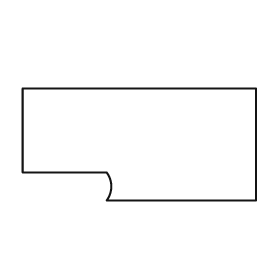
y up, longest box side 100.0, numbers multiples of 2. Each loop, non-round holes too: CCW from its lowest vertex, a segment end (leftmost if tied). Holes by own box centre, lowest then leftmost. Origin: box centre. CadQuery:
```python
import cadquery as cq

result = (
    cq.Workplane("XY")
    .moveTo(-14.0, -24.0)
    .lineTo(50.0, -24.0)
    .lineTo(50.0, 24.0)
    .lineTo(-50.0, 24.0)
    .lineTo(-50.0, -12.0)
    .lineTo(-14.0, -12.0)
    .threePointArc((-12.0, -18.0), (-14.0, -24.0))
    .close()
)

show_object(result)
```